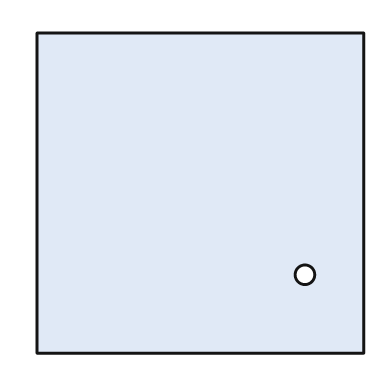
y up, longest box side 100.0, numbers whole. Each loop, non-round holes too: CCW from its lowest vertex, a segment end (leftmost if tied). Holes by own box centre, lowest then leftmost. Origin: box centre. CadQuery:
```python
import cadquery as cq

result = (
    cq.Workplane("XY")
    .moveTo(-50.0, -49.0)
    .lineTo(50.0, -49.0)
    .lineTo(50.0, 49.0)
    .lineTo(-50.0, 49.0)
    .close()
    .moveTo(32.0, -25.0)
    .circle(3.0)
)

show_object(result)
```